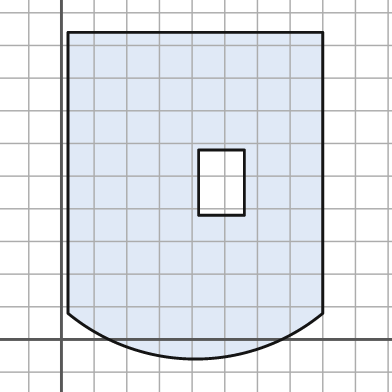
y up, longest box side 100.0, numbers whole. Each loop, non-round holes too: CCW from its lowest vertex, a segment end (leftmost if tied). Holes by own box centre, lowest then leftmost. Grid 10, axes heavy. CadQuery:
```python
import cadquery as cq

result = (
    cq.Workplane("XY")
    .moveTo(2.0, 8.0)
    .threePointArc((41.0, -6.0), (80.0, 8.0))
    .lineTo(80.0, 94.0)
    .lineTo(2.0, 94.0)
    .close()
    .moveTo(42.0, 38.0)
    .lineTo(56.0, 38.0)
    .lineTo(56.0, 58.0)
    .lineTo(42.0, 58.0)
    .close()
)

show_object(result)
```